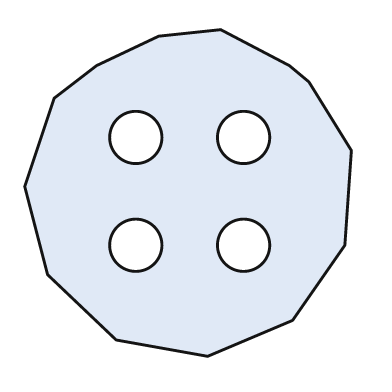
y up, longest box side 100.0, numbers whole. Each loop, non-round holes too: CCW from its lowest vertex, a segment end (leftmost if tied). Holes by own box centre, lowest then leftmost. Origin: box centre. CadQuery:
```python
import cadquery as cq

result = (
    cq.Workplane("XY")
    .moveTo(6.0, -50.0)
    .lineTo(32.0, -39.0)
    .lineTo(48.0, -16.0)
    .lineTo(50.0, 13.0)
    .lineTo(37.0, 34.0)
    .lineTo(31.0, 39.0)
    .lineTo(10.0, 50.0)
    .lineTo(-9.0, 48.0)
    .lineTo(-28.0, 39.0)
    .lineTo(-41.0, 29.0)
    .lineTo(-50.0, 2.0)
    .lineTo(-43.0, -25.0)
    .lineTo(-22.0, -45.0)
    .close()
    .moveTo(-16.0, -16.0)
    .circle(8.0)
    .moveTo(17.0, -16.0)
    .circle(8.0)
    .moveTo(-16.0, 17.0)
    .circle(8.0)
    .moveTo(17.0, 17.0)
    .circle(8.0)
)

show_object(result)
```